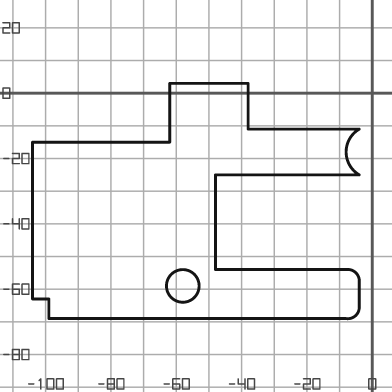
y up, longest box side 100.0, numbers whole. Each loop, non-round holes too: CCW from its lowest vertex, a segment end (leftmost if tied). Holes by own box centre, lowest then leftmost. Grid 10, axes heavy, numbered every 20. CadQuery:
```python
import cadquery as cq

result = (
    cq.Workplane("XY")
    .moveTo(-99.0, -69.0)
    .lineTo(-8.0, -69.0)
    .threePointArc((-5.0, -68.0), (-4.0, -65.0))
    .lineTo(-4.0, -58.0)
    .threePointArc((-5.0, -55.0), (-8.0, -54.0))
    .lineTo(-48.0, -54.0)
    .lineTo(-48.0, -25.0)
    .lineTo(-4.0, -25.0)
    .threePointArc((-8.0, -18.0), (-4.0, -11.0))
    .lineTo(-38.0, -11.0)
    .lineTo(-38.0, 3.0)
    .lineTo(-62.0, 3.0)
    .lineTo(-62.0, -15.0)
    .lineTo(-104.0, -15.0)
    .lineTo(-104.0, -63.0)
    .lineTo(-99.0, -63.0)
    .close()
    .moveTo(-58.0, -59.0)
    .circle(5.0)
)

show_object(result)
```